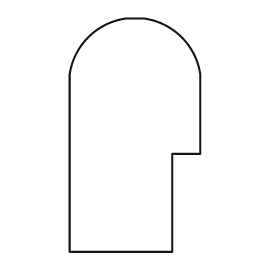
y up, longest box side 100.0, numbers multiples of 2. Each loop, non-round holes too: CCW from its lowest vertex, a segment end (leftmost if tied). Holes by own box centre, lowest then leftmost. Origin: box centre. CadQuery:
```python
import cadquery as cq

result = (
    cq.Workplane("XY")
    .moveTo(-28.0, -50.0)
    .lineTo(16.0, -50.0)
    .lineTo(16.0, -8.0)
    .lineTo(28.0, -8.0)
    .lineTo(28.0, 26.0)
    .threePointArc((20.0, 42.0), (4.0, 50.0))
    .lineTo(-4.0, 50.0)
    .threePointArc((-20.0, 42.0), (-28.0, 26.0))
    .close()
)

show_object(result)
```